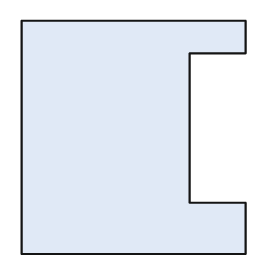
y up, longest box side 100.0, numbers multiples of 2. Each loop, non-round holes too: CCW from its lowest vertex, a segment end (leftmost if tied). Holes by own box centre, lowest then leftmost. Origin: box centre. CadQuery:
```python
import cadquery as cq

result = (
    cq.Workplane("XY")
    .moveTo(-48.0, -50.0)
    .lineTo(48.0, -50.0)
    .lineTo(48.0, -28.0)
    .lineTo(24.0, -28.0)
    .lineTo(24.0, 36.0)
    .lineTo(48.0, 36.0)
    .lineTo(48.0, 50.0)
    .lineTo(-48.0, 50.0)
    .close()
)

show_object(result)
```